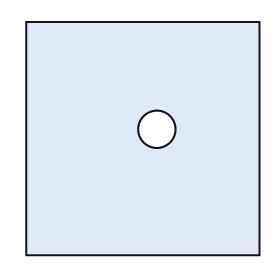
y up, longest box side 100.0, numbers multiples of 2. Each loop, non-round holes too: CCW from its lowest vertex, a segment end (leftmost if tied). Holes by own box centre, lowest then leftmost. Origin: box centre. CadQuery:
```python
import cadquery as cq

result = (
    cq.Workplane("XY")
    .moveTo(-50.0, -50.0)
    .lineTo(50.0, -50.0)
    .lineTo(50.0, 50.0)
    .lineTo(-50.0, 50.0)
    .close()
    .moveTo(6.0, 4.0)
    .circle(8.0)
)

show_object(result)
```